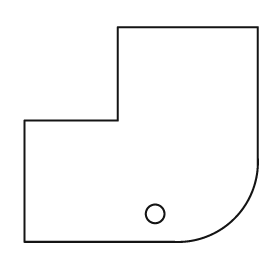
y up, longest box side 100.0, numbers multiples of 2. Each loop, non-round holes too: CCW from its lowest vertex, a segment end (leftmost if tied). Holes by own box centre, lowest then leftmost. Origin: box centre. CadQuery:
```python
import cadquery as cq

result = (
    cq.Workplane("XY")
    .moveTo(-50.0, -46.0)
    .lineTo(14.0, -46.0)
    .threePointArc((40.0, -36.0), (50.0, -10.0))
    .lineTo(50.0, 46.0)
    .lineTo(-10.0, 46.0)
    .lineTo(-10.0, 6.0)
    .lineTo(-50.0, 6.0)
    .close()
    .moveTo(6.0, -34.0)
    .circle(4.0)
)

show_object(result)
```